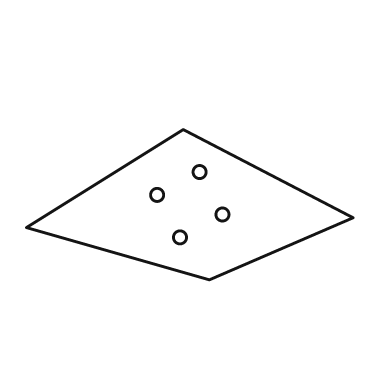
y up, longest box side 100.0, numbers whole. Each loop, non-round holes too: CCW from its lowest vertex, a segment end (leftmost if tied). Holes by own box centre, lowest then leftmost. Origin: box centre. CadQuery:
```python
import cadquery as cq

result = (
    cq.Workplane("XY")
    .moveTo(6.0, -23.0)
    .lineTo(50.0, -4.0)
    .lineTo(-2.0, 23.0)
    .lineTo(-50.0, -7.0)
    .close()
    .moveTo(-3.0, -10.0)
    .circle(2.0)
    .moveTo(10.0, -3.0)
    .circle(2.0)
    .moveTo(-10.0, 3.0)
    .circle(2.0)
    .moveTo(3.0, 10.0)
    .circle(2.0)
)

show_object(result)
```